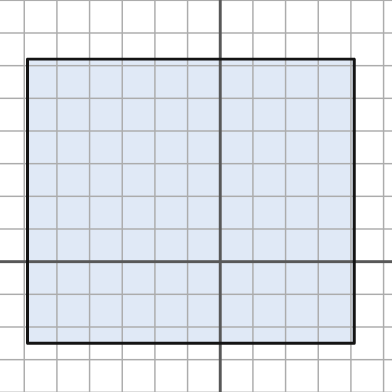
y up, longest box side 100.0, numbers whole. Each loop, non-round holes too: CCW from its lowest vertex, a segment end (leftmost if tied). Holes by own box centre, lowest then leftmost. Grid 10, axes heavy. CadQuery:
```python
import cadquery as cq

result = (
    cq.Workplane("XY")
    .moveTo(-59.0, -25.0)
    .lineTo(41.0, -25.0)
    .lineTo(41.0, 62.0)
    .lineTo(-59.0, 62.0)
    .close()
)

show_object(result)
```